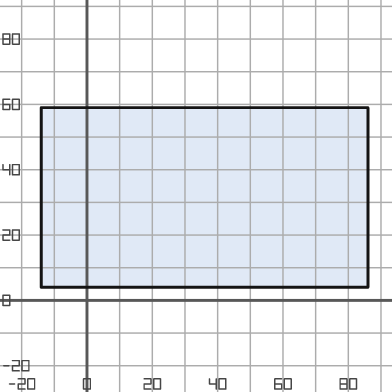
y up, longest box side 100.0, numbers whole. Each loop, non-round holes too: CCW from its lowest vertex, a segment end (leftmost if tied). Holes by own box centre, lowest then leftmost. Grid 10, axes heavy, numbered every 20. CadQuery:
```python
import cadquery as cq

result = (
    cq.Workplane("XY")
    .moveTo(-14.0, 4.0)
    .lineTo(86.0, 4.0)
    .lineTo(86.0, 59.0)
    .lineTo(-14.0, 59.0)
    .close()
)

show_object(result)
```